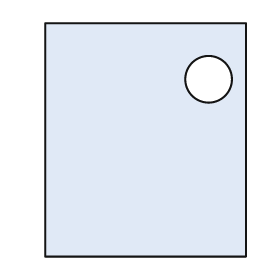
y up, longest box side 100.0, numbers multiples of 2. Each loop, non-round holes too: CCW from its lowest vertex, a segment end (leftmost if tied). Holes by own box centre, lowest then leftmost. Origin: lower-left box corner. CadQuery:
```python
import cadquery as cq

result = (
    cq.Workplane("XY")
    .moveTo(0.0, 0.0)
    .lineTo(86.0, 0.0)
    .lineTo(86.0, 100.0)
    .lineTo(0.0, 100.0)
    .close()
    .moveTo(70.0, 76.0)
    .circle(10.0)
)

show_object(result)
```